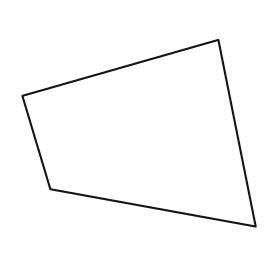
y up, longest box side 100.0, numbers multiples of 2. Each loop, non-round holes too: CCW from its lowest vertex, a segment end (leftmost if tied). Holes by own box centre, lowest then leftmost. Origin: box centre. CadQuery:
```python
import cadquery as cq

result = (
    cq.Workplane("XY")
    .moveTo(50.0, -40.0)
    .lineTo(34.0, 40.0)
    .lineTo(-50.0, 16.0)
    .lineTo(-38.0, -24.0)
    .close()
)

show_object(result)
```